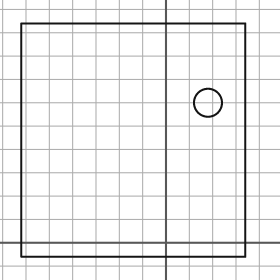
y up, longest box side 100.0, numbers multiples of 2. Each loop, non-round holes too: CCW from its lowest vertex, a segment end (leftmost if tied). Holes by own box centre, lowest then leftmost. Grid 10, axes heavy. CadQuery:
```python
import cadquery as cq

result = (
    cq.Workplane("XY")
    .moveTo(-62.0, -6.0)
    .lineTo(34.0, -6.0)
    .lineTo(34.0, 94.0)
    .lineTo(-62.0, 94.0)
    .close()
    .moveTo(18.0, 60.0)
    .circle(6.0)
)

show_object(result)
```